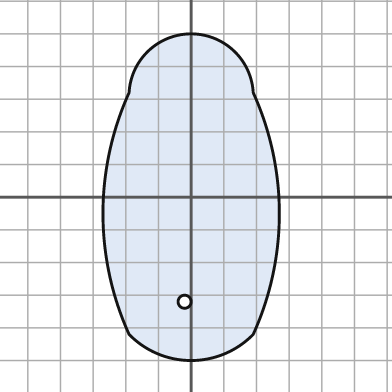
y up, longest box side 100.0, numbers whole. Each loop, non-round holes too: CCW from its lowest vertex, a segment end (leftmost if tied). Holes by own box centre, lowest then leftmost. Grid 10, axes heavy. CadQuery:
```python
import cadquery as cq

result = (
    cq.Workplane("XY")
    .moveTo(-19.0, -42.0)
    .threePointArc((0.0, -50.0), (19.0, -42.0))
    .threePointArc((27.0, -5.0), (19.0, 32.0))
    .threePointArc((0.0, 50.0), (-19.0, 32.0))
    .threePointArc((-27.0, -5.0), (-19.0, -42.0))
    .close()
    .moveTo(-2.0, -32.0)
    .circle(2.0)
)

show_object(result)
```